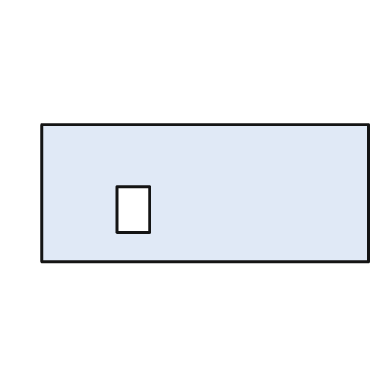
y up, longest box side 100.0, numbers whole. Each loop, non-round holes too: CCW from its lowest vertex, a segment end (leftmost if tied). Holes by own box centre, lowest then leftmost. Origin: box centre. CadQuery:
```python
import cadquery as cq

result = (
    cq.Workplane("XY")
    .moveTo(-50.0, -21.0)
    .lineTo(50.0, -21.0)
    .lineTo(50.0, 21.0)
    .lineTo(-50.0, 21.0)
    .close()
    .moveTo(-27.0, -12.0)
    .lineTo(-17.0, -12.0)
    .lineTo(-17.0, 2.0)
    .lineTo(-27.0, 2.0)
    .close()
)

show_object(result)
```